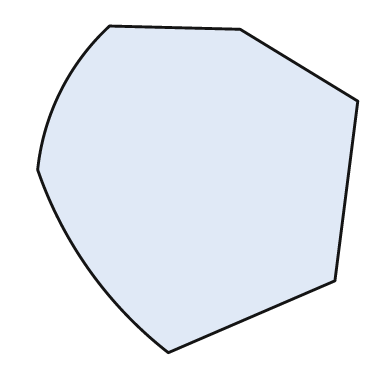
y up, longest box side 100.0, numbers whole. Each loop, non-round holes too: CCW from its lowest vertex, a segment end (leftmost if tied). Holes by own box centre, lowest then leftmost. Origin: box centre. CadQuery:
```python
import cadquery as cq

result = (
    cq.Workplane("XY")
    .moveTo(-9.0, -50.0)
    .lineTo(42.0, -28.0)
    .lineTo(49.0, 27.0)
    .lineTo(13.0, 49.0)
    .lineTo(-27.0, 50.0)
    .threePointArc((-42.0, 30.0), (-49.0, 6.0))
    .threePointArc((-33.0, -25.0), (-9.0, -50.0))
    .close()
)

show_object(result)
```